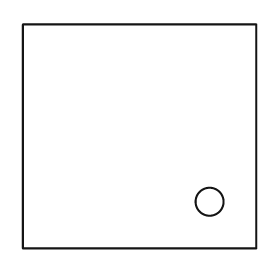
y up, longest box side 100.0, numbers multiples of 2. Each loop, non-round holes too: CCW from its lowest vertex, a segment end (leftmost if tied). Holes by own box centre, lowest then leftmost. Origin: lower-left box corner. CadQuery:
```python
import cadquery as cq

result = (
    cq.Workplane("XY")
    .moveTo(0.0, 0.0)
    .lineTo(100.0, 0.0)
    .lineTo(100.0, 96.0)
    .lineTo(0.0, 96.0)
    .close()
    .moveTo(80.0, 20.0)
    .circle(6.0)
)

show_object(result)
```